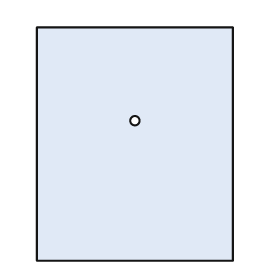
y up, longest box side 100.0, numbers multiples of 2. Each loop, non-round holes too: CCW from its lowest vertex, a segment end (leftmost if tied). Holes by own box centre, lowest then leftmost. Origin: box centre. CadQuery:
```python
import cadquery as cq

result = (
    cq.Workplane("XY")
    .moveTo(-42.0, -50.0)
    .lineTo(42.0, -50.0)
    .lineTo(42.0, 50.0)
    .lineTo(-42.0, 50.0)
    .close()
    .moveTo(0.0, 10.0)
    .circle(2.0)
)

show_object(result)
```